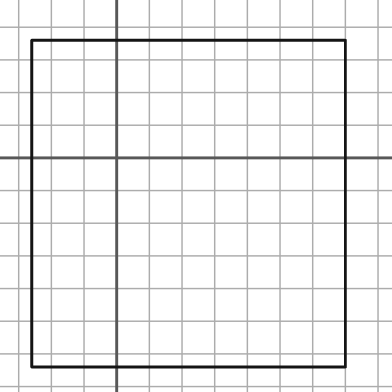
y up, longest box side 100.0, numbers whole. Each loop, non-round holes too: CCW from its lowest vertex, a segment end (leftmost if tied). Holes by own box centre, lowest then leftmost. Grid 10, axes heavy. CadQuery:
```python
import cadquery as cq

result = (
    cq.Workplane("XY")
    .moveTo(-26.0, -64.0)
    .lineTo(70.0, -64.0)
    .lineTo(70.0, 36.0)
    .lineTo(-26.0, 36.0)
    .close()
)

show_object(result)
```